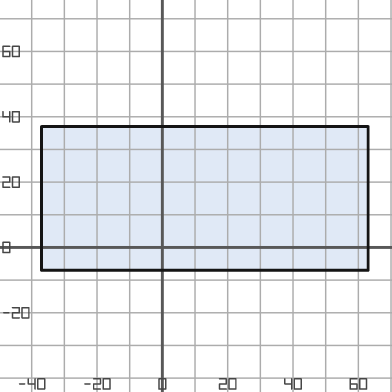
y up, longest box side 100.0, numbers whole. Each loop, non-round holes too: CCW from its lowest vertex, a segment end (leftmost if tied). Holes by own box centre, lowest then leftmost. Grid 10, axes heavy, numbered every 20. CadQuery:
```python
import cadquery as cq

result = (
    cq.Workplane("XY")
    .moveTo(-37.0, -7.0)
    .lineTo(63.0, -7.0)
    .lineTo(63.0, 37.0)
    .lineTo(-37.0, 37.0)
    .close()
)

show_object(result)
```